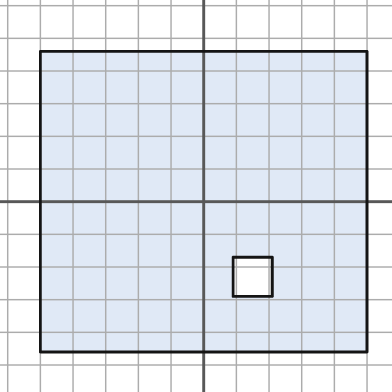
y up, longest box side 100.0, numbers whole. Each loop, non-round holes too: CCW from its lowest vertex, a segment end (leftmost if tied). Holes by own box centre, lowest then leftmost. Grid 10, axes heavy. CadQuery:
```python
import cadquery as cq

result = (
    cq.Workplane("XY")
    .moveTo(-50.0, -46.0)
    .lineTo(50.0, -46.0)
    .lineTo(50.0, 46.0)
    .lineTo(-50.0, 46.0)
    .close()
    .moveTo(9.0, -29.0)
    .lineTo(21.0, -29.0)
    .lineTo(21.0, -17.0)
    .lineTo(9.0, -17.0)
    .close()
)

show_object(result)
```